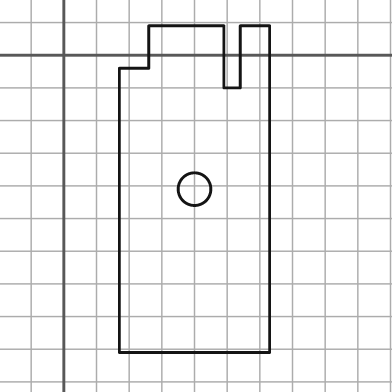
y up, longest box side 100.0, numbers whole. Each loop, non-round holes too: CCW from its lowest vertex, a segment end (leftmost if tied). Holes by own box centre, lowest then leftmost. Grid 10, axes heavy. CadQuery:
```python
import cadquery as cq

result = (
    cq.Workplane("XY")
    .moveTo(17.0, -91.0)
    .lineTo(63.0, -91.0)
    .lineTo(63.0, 9.0)
    .lineTo(54.0, 9.0)
    .lineTo(54.0, -10.0)
    .lineTo(49.0, -10.0)
    .lineTo(49.0, 9.0)
    .lineTo(26.0, 9.0)
    .lineTo(26.0, -4.0)
    .lineTo(17.0, -4.0)
    .close()
    .moveTo(40.0, -41.0)
    .circle(5.0)
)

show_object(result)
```